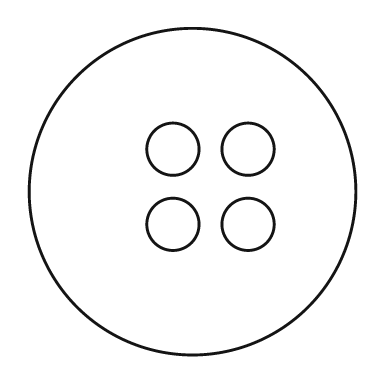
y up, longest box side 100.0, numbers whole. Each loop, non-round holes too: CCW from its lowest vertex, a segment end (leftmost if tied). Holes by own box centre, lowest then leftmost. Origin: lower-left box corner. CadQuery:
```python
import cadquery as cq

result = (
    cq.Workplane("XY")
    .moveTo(50.0, 50.0)
    .circle(50.0)
    .moveTo(44.0, 40.0)
    .circle(8.0)
    .moveTo(67.0, 40.0)
    .circle(8.0)
    .moveTo(44.0, 63.0)
    .circle(8.0)
    .moveTo(67.0, 63.0)
    .circle(8.0)
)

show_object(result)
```